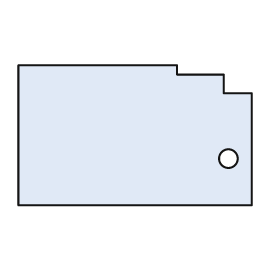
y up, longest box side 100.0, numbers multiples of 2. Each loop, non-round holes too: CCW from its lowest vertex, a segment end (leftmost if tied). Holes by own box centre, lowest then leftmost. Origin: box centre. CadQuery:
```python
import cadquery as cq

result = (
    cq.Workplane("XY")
    .moveTo(-50.0, -30.0)
    .lineTo(50.0, -30.0)
    .lineTo(50.0, 18.0)
    .lineTo(38.0, 18.0)
    .lineTo(38.0, 26.0)
    .lineTo(18.0, 26.0)
    .lineTo(18.0, 30.0)
    .lineTo(-50.0, 30.0)
    .close()
    .moveTo(40.0, -10.0)
    .circle(4.0)
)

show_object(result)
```